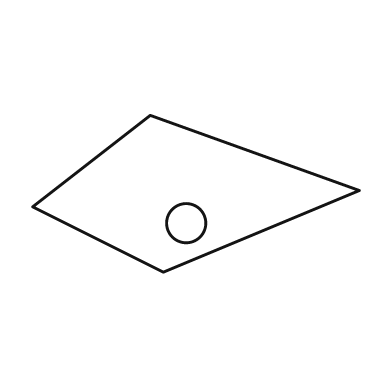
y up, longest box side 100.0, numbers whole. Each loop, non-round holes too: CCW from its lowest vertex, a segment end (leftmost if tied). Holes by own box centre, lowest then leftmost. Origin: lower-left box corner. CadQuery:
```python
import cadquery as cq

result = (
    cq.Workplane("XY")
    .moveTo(40.0, 0.0)
    .lineTo(100.0, 25.0)
    .lineTo(36.0, 48.0)
    .lineTo(0.0, 20.0)
    .close()
    .moveTo(47.0, 15.0)
    .circle(6.0)
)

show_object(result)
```